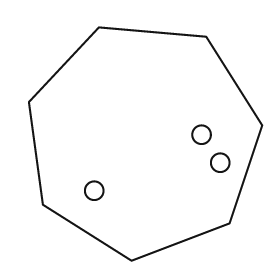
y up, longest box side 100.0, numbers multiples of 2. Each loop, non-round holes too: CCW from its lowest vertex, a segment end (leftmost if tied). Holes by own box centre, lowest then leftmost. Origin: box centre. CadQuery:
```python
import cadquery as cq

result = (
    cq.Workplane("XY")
    .moveTo(-6.0, -50.0)
    .lineTo(36.0, -34.0)
    .lineTo(50.0, 8.0)
    .lineTo(26.0, 46.0)
    .lineTo(-20.0, 50.0)
    .lineTo(-50.0, 18.0)
    .lineTo(-44.0, -26.0)
    .close()
    .moveTo(-22.0, -20.0)
    .circle(4.0)
    .moveTo(32.0, -8.0)
    .circle(4.0)
    .moveTo(24.0, 4.0)
    .circle(4.0)
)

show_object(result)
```